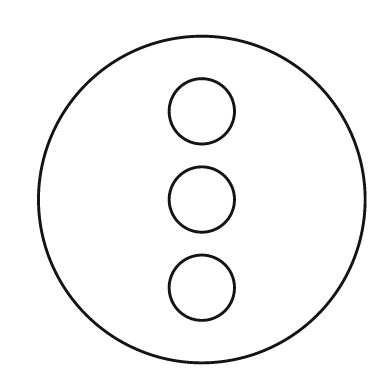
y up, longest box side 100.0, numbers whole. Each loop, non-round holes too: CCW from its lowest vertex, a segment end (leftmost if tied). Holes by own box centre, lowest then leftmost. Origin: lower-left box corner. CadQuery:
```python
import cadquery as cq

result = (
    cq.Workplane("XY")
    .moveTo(50.0, 50.0)
    .circle(50.0)
    .moveTo(50.0, 23.0)
    .circle(10.0)
    .moveTo(50.0, 50.0)
    .circle(10.0)
    .moveTo(50.0, 77.0)
    .circle(10.0)
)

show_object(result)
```